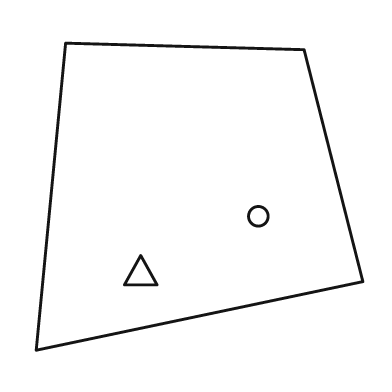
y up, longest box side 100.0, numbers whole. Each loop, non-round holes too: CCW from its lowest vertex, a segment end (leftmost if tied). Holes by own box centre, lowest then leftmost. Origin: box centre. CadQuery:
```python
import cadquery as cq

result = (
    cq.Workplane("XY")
    .moveTo(-50.0, -47.0)
    .lineTo(50.0, -26.0)
    .lineTo(32.0, 45.0)
    .lineTo(-41.0, 47.0)
    .close()
    .moveTo(-23.0, -27.0)
    .lineTo(-13.0, -27.0)
    .lineTo(-18.0, -18.0)
    .close()
    .moveTo(18.0, -6.0)
    .circle(3.0)
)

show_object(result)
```